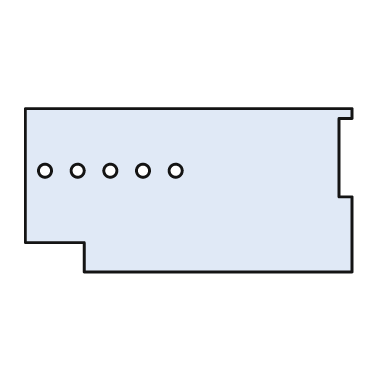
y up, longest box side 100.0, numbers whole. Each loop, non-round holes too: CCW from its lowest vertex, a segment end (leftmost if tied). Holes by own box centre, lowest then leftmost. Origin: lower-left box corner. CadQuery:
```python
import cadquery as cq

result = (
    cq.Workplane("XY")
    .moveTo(18.0, 0.0)
    .lineTo(100.0, 0.0)
    .lineTo(100.0, 23.0)
    .lineTo(96.0, 23.0)
    .lineTo(96.0, 47.0)
    .lineTo(100.0, 47.0)
    .lineTo(100.0, 50.0)
    .lineTo(0.0, 50.0)
    .lineTo(0.0, 9.0)
    .lineTo(18.0, 9.0)
    .close()
    .moveTo(6.0, 31.0)
    .circle(2.0)
    .moveTo(16.0, 31.0)
    .circle(2.0)
    .moveTo(26.0, 31.0)
    .circle(2.0)
    .moveTo(36.0, 31.0)
    .circle(2.0)
    .moveTo(46.0, 31.0)
    .circle(2.0)
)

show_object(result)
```